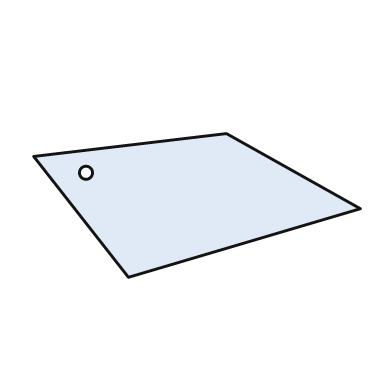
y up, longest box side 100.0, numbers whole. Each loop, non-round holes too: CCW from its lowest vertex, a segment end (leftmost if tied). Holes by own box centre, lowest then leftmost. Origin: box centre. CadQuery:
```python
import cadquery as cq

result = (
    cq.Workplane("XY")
    .moveTo(-21.0, -22.0)
    .lineTo(50.0, -1.0)
    .lineTo(9.0, 22.0)
    .lineTo(-50.0, 15.0)
    .close()
    .moveTo(-34.0, 10.0)
    .circle(2.0)
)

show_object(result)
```